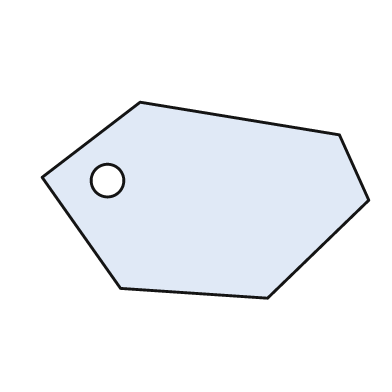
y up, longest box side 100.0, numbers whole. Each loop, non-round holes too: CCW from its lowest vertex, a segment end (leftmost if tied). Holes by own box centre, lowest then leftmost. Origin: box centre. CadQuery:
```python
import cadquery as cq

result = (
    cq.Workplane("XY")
    .moveTo(19.0, -30.0)
    .lineTo(50.0, 0.0)
    .lineTo(41.0, 20.0)
    .lineTo(-20.0, 30.0)
    .lineTo(-50.0, 7.0)
    .lineTo(-26.0, -27.0)
    .close()
    .moveTo(-30.0, 6.0)
    .circle(5.0)
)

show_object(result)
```